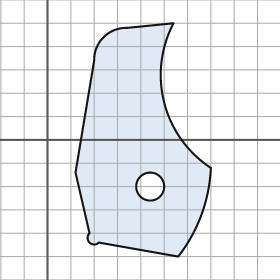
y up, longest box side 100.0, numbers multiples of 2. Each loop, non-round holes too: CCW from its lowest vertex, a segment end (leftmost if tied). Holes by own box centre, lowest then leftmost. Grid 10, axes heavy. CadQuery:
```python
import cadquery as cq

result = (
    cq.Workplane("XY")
    .moveTo(56.0, -50.0)
    .threePointArc((66.0, -32.0), (70.0, -12.0))
    .threePointArc((50.0, 16.0), (54.0, 50.0))
    .lineTo(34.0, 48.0)
    .threePointArc((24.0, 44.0), (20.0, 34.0))
    .lineTo(12.0, -14.0)
    .lineTo(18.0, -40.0)
    .threePointArc((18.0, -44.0), (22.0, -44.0))
    .close()
    .moveTo(44.0, -20.0)
    .circle(6.0)
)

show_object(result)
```